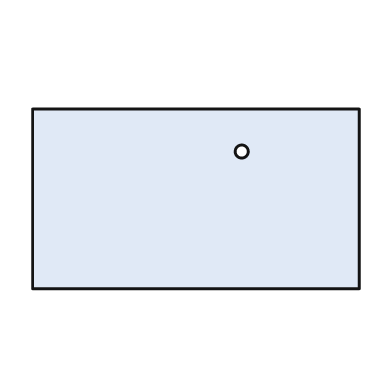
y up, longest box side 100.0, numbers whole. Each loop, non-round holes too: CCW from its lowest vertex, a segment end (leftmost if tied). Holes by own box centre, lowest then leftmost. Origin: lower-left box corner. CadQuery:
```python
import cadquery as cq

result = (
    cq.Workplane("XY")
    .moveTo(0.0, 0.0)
    .lineTo(100.0, 0.0)
    .lineTo(100.0, 55.0)
    .lineTo(0.0, 55.0)
    .close()
    .moveTo(64.0, 42.0)
    .circle(2.0)
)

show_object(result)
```